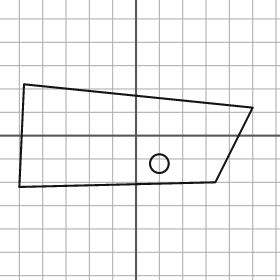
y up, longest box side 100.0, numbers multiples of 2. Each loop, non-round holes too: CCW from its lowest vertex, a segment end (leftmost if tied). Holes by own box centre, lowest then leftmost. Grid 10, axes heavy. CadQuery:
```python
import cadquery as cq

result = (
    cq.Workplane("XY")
    .moveTo(-50.0, -22.0)
    .lineTo(34.0, -20.0)
    .lineTo(50.0, 12.0)
    .lineTo(-48.0, 22.0)
    .close()
    .moveTo(10.0, -12.0)
    .circle(4.0)
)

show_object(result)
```